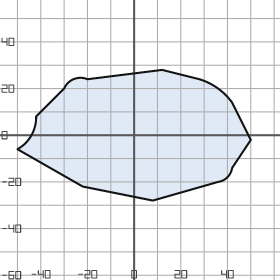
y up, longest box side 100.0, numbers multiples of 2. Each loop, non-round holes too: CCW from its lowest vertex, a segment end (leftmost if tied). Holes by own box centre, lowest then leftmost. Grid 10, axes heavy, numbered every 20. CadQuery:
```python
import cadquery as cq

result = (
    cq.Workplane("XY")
    .moveTo(8.0, -28.0)
    .lineTo(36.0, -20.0)
    .threePointArc((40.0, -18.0), (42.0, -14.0))
    .lineTo(50.0, -2.0)
    .lineTo(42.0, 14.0)
    .threePointArc((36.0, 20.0), (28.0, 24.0))
    .lineTo(12.0, 28.0)
    .lineTo(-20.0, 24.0)
    .threePointArc((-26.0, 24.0), (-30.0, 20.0))
    .lineTo(-42.0, 8.0)
    .threePointArc((-44.0, 0.0), (-50.0, -6.0))
    .lineTo(-22.0, -22.0)
    .close()
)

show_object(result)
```